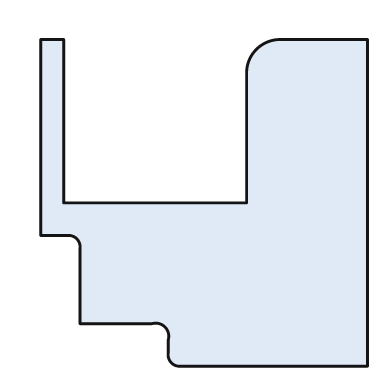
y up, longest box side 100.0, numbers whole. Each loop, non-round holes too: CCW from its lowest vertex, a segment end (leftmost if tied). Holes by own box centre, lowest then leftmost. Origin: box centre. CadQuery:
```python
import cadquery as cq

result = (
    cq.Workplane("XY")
    .moveTo(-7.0, -50.0)
    .lineTo(50.0, -50.0)
    .lineTo(50.0, 50.0)
    .lineTo(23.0, 50.0)
    .threePointArc((16.0, 47.0), (13.0, 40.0))
    .lineTo(13.0, 0.0)
    .lineTo(-43.0, 0.0)
    .lineTo(-43.0, 50.0)
    .lineTo(-50.0, 50.0)
    .lineTo(-50.0, -10.0)
    .lineTo(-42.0, -10.0)
    .threePointArc((-39.0, -11.0), (-38.0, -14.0))
    .lineTo(-38.0, -37.0)
    .lineTo(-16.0, -37.0)
    .threePointArc((-12.0, -38.0), (-11.0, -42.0))
    .lineTo(-11.0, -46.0)
    .threePointArc((-10.0, -49.0), (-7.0, -50.0))
    .close()
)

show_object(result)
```